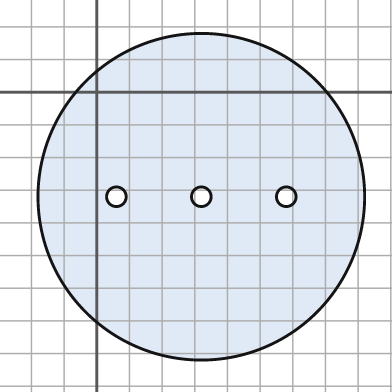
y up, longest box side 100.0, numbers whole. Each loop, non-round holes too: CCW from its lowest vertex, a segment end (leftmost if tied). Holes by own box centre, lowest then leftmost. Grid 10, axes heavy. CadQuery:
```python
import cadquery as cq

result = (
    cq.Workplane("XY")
    .moveTo(32.0, -32.0)
    .circle(50.0)
    .moveTo(6.0, -32.0)
    .circle(3.0)
    .moveTo(32.0, -32.0)
    .circle(3.0)
    .moveTo(58.0, -32.0)
    .circle(3.0)
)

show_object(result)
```